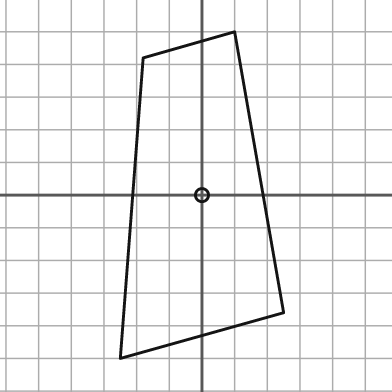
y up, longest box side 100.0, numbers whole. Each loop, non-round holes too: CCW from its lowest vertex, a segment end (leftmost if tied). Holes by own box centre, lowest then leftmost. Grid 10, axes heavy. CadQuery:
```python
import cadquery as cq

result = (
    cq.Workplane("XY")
    .moveTo(-25.0, -50.0)
    .lineTo(25.0, -36.0)
    .lineTo(10.0, 50.0)
    .lineTo(-18.0, 42.0)
    .close()
    .moveTo(0.0, 0.0)
    .circle(2.0)
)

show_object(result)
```